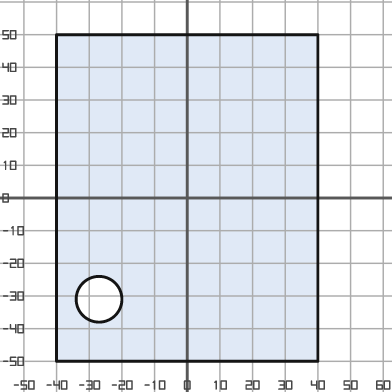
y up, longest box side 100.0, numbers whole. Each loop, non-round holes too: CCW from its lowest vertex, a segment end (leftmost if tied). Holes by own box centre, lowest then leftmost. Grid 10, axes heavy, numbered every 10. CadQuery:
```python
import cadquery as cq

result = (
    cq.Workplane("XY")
    .moveTo(-40.0, -50.0)
    .lineTo(40.0, -50.0)
    .lineTo(40.0, 50.0)
    .lineTo(-40.0, 50.0)
    .close()
    .moveTo(-27.0, -31.0)
    .circle(7.0)
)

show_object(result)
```